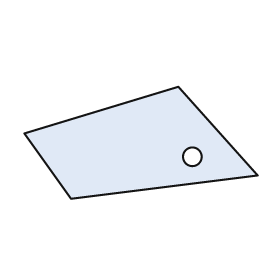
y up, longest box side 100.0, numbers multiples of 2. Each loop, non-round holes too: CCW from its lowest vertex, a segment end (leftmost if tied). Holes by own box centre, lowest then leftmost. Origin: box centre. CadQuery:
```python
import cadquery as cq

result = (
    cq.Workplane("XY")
    .moveTo(-30.0, -24.0)
    .lineTo(50.0, -14.0)
    .lineTo(16.0, 24.0)
    .lineTo(-50.0, 4.0)
    .close()
    .moveTo(22.0, -6.0)
    .circle(4.0)
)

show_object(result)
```